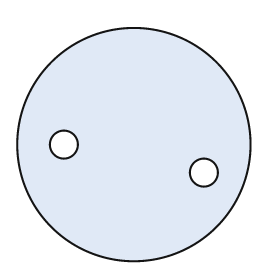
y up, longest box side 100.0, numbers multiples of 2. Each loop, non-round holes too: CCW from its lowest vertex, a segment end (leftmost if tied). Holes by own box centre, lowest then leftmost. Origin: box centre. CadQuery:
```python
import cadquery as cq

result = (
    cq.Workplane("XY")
    .moveTo(0.0, 0.0)
    .circle(50.0)
    .moveTo(30.0, -12.0)
    .circle(6.0)
    .moveTo(-30.0, 0.0)
    .circle(6.0)
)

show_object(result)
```